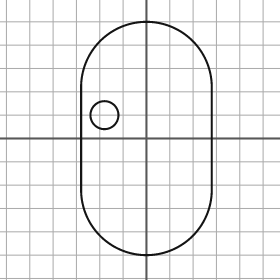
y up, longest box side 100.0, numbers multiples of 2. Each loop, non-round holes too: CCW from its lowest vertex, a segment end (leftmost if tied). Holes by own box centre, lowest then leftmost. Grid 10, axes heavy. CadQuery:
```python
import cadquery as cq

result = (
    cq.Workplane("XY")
    .moveTo(-28.0, -22.0)
    .threePointArc((0.0, -50.0), (28.0, -22.0))
    .lineTo(28.0, 22.0)
    .threePointArc((0.0, 50.0), (-28.0, 22.0))
    .close()
    .moveTo(-18.0, 10.0)
    .circle(6.0)
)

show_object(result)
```